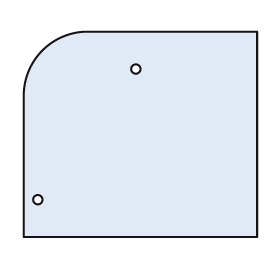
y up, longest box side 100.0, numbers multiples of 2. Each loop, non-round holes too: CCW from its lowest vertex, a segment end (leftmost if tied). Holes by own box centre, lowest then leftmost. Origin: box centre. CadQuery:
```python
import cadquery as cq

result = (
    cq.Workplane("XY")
    .moveTo(-50.0, -44.0)
    .lineTo(50.0, -44.0)
    .lineTo(50.0, 44.0)
    .lineTo(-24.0, 44.0)
    .threePointArc((-42.0, 36.0), (-50.0, 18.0))
    .close()
    .moveTo(-44.0, -28.0)
    .circle(2.0)
    .moveTo(-2.0, 28.0)
    .circle(2.0)
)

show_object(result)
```